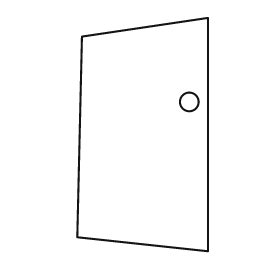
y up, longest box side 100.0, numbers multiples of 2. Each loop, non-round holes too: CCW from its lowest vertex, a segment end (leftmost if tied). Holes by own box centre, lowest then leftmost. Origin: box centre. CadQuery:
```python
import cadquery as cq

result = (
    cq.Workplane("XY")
    .moveTo(28.0, -50.0)
    .lineTo(28.0, 50.0)
    .lineTo(-26.0, 42.0)
    .lineTo(-28.0, -44.0)
    .close()
    .moveTo(20.0, 14.0)
    .circle(4.0)
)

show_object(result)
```